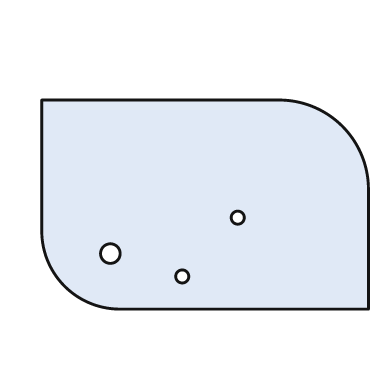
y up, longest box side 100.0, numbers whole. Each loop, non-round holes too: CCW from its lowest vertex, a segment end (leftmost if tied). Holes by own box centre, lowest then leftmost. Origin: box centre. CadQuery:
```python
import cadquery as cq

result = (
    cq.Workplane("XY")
    .moveTo(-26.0, -32.0)
    .lineTo(50.0, -32.0)
    .lineTo(50.0, 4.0)
    .threePointArc((42.0, 24.0), (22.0, 32.0))
    .lineTo(-50.0, 32.0)
    .lineTo(-50.0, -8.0)
    .threePointArc((-43.0, -25.0), (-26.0, -32.0))
    .close()
    .moveTo(-7.0, -22.0)
    .circle(2.0)
    .moveTo(-29.0, -15.0)
    .circle(3.0)
    .moveTo(10.0, -4.0)
    .circle(2.0)
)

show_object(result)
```